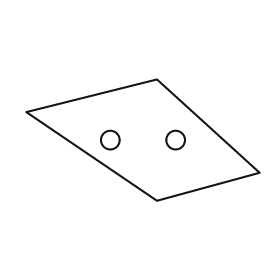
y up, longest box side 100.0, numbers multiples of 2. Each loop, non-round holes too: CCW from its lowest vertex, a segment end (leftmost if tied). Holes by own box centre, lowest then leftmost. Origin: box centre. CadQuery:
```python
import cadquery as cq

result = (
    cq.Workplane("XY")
    .moveTo(6.0, -26.0)
    .lineTo(50.0, -14.0)
    .lineTo(6.0, 26.0)
    .lineTo(-50.0, 12.0)
    .close()
    .moveTo(-14.0, 0.0)
    .circle(4.0)
    .moveTo(14.0, 0.0)
    .circle(4.0)
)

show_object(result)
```